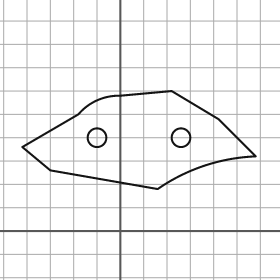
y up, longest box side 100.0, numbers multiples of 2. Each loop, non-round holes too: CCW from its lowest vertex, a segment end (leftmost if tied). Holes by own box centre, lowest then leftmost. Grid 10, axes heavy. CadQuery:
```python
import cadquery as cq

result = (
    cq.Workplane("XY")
    .moveTo(16.0, 18.0)
    .threePointArc((36.0, 28.0), (58.0, 32.0))
    .lineTo(42.0, 48.0)
    .lineTo(22.0, 60.0)
    .lineTo(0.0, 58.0)
    .threePointArc((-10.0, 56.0), (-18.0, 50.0))
    .lineTo(-42.0, 36.0)
    .lineTo(-30.0, 26.0)
    .close()
    .moveTo(-10.0, 40.0)
    .circle(4.0)
    .moveTo(26.0, 40.0)
    .circle(4.0)
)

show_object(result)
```